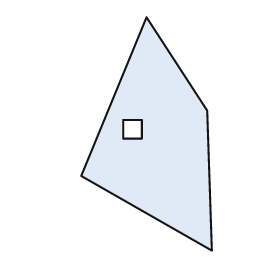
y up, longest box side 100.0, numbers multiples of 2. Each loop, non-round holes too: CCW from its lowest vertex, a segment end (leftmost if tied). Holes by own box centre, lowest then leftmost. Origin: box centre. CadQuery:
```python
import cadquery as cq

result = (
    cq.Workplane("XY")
    .moveTo(28.0, -50.0)
    .lineTo(26.0, 10.0)
    .lineTo(0.0, 50.0)
    .lineTo(-28.0, -18.0)
    .close()
    .moveTo(-10.0, -2.0)
    .lineTo(-2.0, -2.0)
    .lineTo(-2.0, 6.0)
    .lineTo(-10.0, 6.0)
    .close()
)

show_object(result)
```